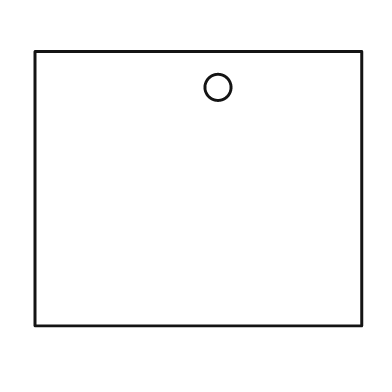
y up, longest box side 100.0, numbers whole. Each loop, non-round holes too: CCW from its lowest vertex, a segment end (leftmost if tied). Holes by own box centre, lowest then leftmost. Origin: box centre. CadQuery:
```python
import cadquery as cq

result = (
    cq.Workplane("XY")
    .moveTo(-50.0, -42.0)
    .lineTo(50.0, -42.0)
    .lineTo(50.0, 42.0)
    .lineTo(-50.0, 42.0)
    .close()
    .moveTo(6.0, 31.0)
    .circle(4.0)
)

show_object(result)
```